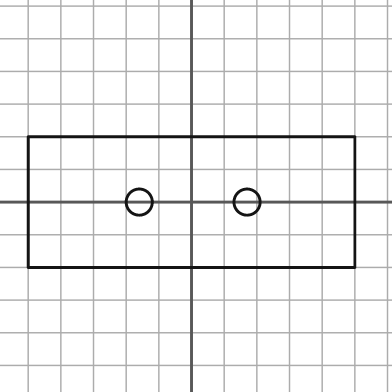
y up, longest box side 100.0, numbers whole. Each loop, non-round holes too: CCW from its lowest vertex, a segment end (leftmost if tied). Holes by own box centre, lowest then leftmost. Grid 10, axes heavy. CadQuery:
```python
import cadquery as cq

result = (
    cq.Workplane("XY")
    .moveTo(-50.0, -20.0)
    .lineTo(50.0, -20.0)
    .lineTo(50.0, 20.0)
    .lineTo(-50.0, 20.0)
    .close()
    .moveTo(-16.0, 0.0)
    .circle(4.0)
    .moveTo(17.0, 0.0)
    .circle(4.0)
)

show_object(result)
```